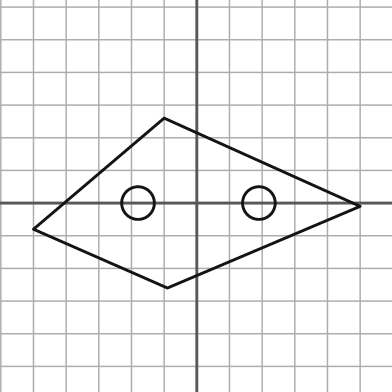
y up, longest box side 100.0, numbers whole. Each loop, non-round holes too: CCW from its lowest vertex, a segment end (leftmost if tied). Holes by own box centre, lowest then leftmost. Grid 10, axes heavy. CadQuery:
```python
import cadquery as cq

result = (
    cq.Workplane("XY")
    .moveTo(-9.0, -26.0)
    .lineTo(50.0, -1.0)
    .lineTo(-10.0, 26.0)
    .lineTo(-50.0, -8.0)
    .close()
    .moveTo(-18.0, 0.0)
    .circle(5.0)
    .moveTo(19.0, 0.0)
    .circle(5.0)
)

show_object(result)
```